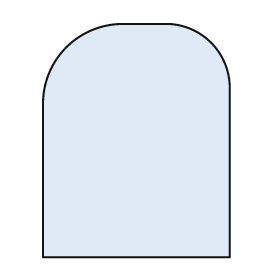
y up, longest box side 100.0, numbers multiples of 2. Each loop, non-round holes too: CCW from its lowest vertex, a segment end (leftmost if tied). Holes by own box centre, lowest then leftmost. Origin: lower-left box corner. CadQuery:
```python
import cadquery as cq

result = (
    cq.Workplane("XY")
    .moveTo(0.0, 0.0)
    .lineTo(80.0, 0.0)
    .lineTo(80.0, 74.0)
    .threePointArc((72.0, 92.0), (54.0, 100.0))
    .lineTo(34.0, 100.0)
    .threePointArc((10.0, 90.0), (0.0, 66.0))
    .close()
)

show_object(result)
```